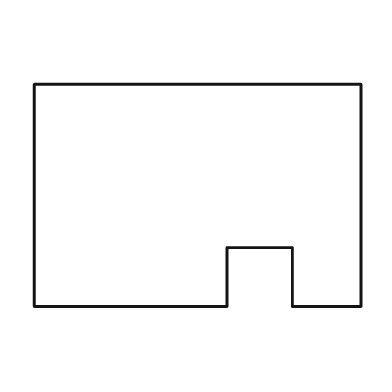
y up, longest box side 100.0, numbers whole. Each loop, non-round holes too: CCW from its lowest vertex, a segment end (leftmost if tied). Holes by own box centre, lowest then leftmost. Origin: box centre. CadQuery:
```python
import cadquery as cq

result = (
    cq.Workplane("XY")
    .moveTo(-50.0, -34.0)
    .lineTo(9.0, -34.0)
    .lineTo(9.0, -16.0)
    .lineTo(29.0, -16.0)
    .lineTo(29.0, -34.0)
    .lineTo(50.0, -34.0)
    .lineTo(50.0, 34.0)
    .lineTo(-50.0, 34.0)
    .close()
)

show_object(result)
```